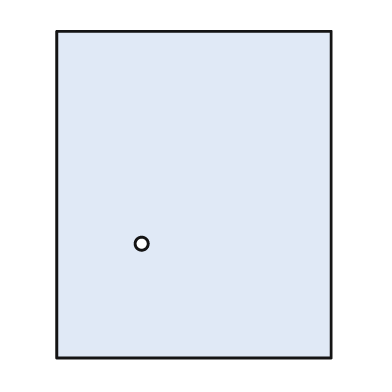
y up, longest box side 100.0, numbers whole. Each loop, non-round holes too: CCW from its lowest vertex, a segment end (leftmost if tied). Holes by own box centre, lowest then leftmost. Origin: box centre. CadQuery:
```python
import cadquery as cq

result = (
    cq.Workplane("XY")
    .moveTo(-42.0, -50.0)
    .lineTo(42.0, -50.0)
    .lineTo(42.0, 50.0)
    .lineTo(-42.0, 50.0)
    .close()
    .moveTo(-16.0, -15.0)
    .circle(2.0)
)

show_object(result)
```